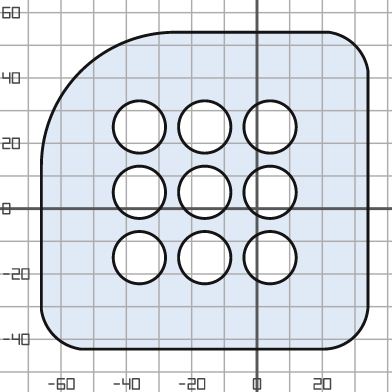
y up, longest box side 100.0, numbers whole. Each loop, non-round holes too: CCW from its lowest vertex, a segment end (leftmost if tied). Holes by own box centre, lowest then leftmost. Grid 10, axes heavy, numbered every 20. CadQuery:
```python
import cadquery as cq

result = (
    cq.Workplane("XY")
    .moveTo(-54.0, -43.0)
    .lineTo(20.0, -43.0)
    .threePointArc((30.0, -39.0), (34.0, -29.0))
    .lineTo(34.0, 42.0)
    .threePointArc((30.0, 50.0), (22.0, 54.0))
    .lineTo(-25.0, 54.0)
    .threePointArc((-54.0, 42.0), (-66.0, 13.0))
    .lineTo(-66.0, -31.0)
    .threePointArc((-62.0, -39.0), (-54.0, -43.0))
    .close()
    .moveTo(-36.0, -15.0)
    .circle(8.0)
    .moveTo(-16.0, -15.0)
    .circle(8.0)
    .moveTo(4.0, -15.0)
    .circle(8.0)
    .moveTo(-36.0, 5.0)
    .circle(8.0)
    .moveTo(-16.0, 5.0)
    .circle(8.0)
    .moveTo(4.0, 5.0)
    .circle(8.0)
    .moveTo(-36.0, 25.0)
    .circle(8.0)
    .moveTo(-16.0, 25.0)
    .circle(8.0)
    .moveTo(4.0, 25.0)
    .circle(8.0)
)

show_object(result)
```